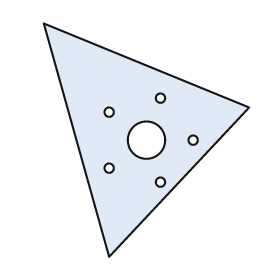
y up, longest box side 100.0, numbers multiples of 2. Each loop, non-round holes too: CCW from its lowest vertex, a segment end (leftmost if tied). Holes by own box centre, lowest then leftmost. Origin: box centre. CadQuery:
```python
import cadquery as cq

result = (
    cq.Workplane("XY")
    .moveTo(-16.0, -50.0)
    .lineTo(44.0, 14.0)
    .lineTo(-44.0, 50.0)
    .close()
    .moveTo(6.0, -18.0)
    .circle(2.0)
    .moveTo(-16.0, -12.0)
    .circle(2.0)
    .moveTo(0.0, 0.0)
    .circle(8.0)
    .moveTo(20.0, 0.0)
    .circle(2.0)
    .moveTo(-16.0, 12.0)
    .circle(2.0)
    .moveTo(6.0, 18.0)
    .circle(2.0)
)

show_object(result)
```